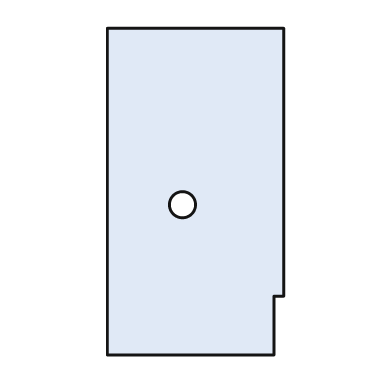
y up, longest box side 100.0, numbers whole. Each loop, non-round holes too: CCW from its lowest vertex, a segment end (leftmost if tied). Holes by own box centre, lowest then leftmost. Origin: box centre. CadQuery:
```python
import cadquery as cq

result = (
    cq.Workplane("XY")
    .moveTo(-27.0, -50.0)
    .lineTo(24.0, -50.0)
    .lineTo(24.0, -32.0)
    .lineTo(27.0, -32.0)
    .lineTo(27.0, 50.0)
    .lineTo(-27.0, 50.0)
    .close()
    .moveTo(-4.0, -4.0)
    .circle(4.0)
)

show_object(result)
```